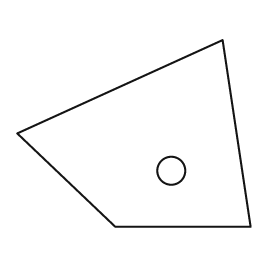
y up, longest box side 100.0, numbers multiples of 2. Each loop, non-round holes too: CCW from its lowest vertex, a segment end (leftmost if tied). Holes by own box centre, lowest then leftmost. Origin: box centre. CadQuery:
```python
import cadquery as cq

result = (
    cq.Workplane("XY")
    .moveTo(-8.0, -40.0)
    .lineTo(50.0, -40.0)
    .lineTo(38.0, 40.0)
    .lineTo(-50.0, 0.0)
    .close()
    .moveTo(16.0, -16.0)
    .circle(6.0)
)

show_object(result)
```